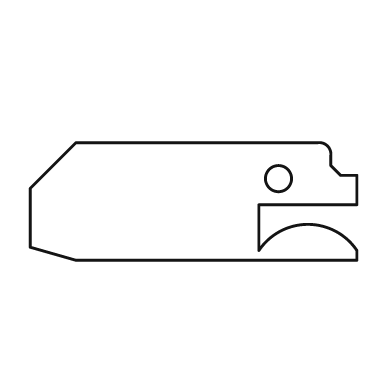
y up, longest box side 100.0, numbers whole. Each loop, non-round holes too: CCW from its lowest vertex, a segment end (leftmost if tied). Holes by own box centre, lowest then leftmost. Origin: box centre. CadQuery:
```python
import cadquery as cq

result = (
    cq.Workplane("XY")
    .moveTo(-36.0, -18.0)
    .lineTo(50.0, -18.0)
    .lineTo(50.0, -15.0)
    .threePointArc((35.0, -7.0), (20.0, -15.0))
    .lineTo(20.0, -1.0)
    .lineTo(50.0, -1.0)
    .lineTo(50.0, 8.0)
    .lineTo(45.0, 8.0)
    .lineTo(42.0, 11.0)
    .lineTo(42.0, 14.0)
    .threePointArc((41.0, 17.0), (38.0, 18.0))
    .lineTo(-36.0, 18.0)
    .lineTo(-50.0, 4.0)
    .lineTo(-50.0, -14.0)
    .close()
    .moveTo(26.0, 7.0)
    .circle(4.0)
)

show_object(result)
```